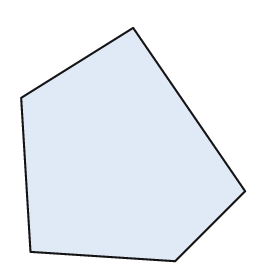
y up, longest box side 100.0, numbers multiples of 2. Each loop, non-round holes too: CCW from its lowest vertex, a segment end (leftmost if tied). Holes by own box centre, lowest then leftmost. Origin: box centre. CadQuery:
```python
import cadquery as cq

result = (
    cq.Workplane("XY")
    .moveTo(18.0, -50.0)
    .lineTo(48.0, -20.0)
    .lineTo(0.0, 50.0)
    .lineTo(-48.0, 20.0)
    .lineTo(-44.0, -46.0)
    .close()
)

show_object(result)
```